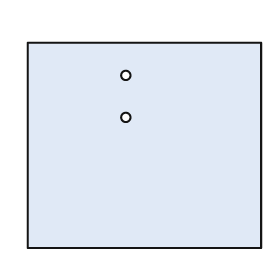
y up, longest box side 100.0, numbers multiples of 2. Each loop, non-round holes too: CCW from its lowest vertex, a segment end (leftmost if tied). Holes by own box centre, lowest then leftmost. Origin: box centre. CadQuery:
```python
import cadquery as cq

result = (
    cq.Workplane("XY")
    .moveTo(-50.0, -44.0)
    .lineTo(50.0, -44.0)
    .lineTo(50.0, 44.0)
    .lineTo(-50.0, 44.0)
    .close()
    .moveTo(-8.0, 12.0)
    .circle(2.0)
    .moveTo(-8.0, 30.0)
    .circle(2.0)
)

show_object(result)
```